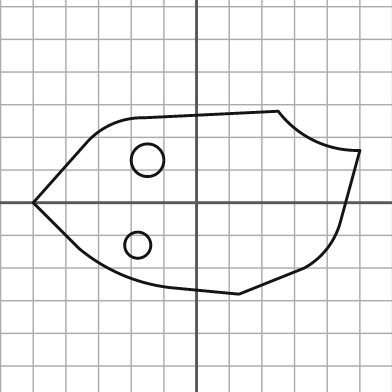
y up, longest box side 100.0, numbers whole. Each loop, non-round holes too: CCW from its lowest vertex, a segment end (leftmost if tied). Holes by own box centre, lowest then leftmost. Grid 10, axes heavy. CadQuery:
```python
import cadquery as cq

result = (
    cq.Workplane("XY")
    .moveTo(13.0, -28.0)
    .lineTo(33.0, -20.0)
    .threePointArc((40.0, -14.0), (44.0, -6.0))
    .lineTo(50.0, 16.0)
    .threePointArc((36.0, 19.0), (25.0, 28.0))
    .lineTo(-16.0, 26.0)
    .threePointArc((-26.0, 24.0), (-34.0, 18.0))
    .lineTo(-50.0, 0.0)
    .lineTo(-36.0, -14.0)
    .threePointArc((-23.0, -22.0), (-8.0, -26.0))
    .close()
    .moveTo(-18.0, -13.0)
    .circle(4.0)
    .moveTo(-15.0, 13.0)
    .circle(5.0)
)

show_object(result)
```